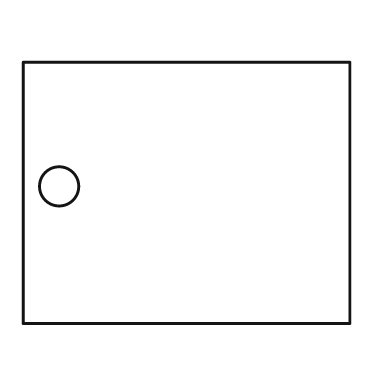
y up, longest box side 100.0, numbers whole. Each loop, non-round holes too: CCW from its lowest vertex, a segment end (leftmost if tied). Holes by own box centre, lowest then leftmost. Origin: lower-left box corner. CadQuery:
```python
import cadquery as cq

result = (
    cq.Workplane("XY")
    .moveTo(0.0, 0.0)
    .lineTo(100.0, 0.0)
    .lineTo(100.0, 80.0)
    .lineTo(0.0, 80.0)
    .close()
    .moveTo(11.0, 42.0)
    .circle(6.0)
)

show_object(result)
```